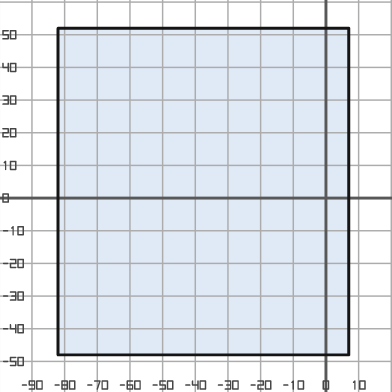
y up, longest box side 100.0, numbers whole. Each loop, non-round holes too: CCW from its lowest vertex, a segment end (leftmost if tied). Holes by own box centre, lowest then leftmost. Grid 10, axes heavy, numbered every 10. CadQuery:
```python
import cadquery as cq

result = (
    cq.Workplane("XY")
    .moveTo(-82.0, -48.0)
    .lineTo(7.0, -48.0)
    .lineTo(7.0, 52.0)
    .lineTo(-82.0, 52.0)
    .close()
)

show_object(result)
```